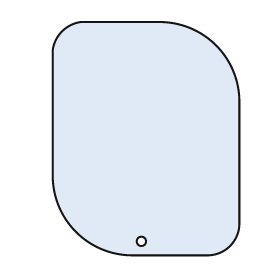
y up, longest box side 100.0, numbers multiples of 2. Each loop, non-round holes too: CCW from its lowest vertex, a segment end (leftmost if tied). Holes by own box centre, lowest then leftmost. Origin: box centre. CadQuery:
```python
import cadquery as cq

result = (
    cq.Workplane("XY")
    .moveTo(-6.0, -50.0)
    .lineTo(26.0, -50.0)
    .threePointArc((36.0, -46.0), (40.0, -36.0))
    .lineTo(40.0, 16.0)
    .threePointArc((30.0, 40.0), (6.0, 50.0))
    .lineTo(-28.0, 50.0)
    .threePointArc((-36.0, 46.0), (-40.0, 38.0))
    .lineTo(-40.0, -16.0)
    .threePointArc((-30.0, -40.0), (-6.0, -50.0))
    .close()
    .moveTo(-2.0, -44.0)
    .circle(2.0)
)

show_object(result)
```